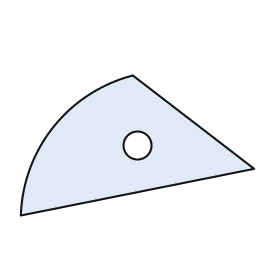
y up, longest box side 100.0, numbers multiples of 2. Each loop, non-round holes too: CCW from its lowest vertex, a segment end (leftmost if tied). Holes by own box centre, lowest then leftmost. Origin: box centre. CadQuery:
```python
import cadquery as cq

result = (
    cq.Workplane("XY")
    .moveTo(-50.0, -30.0)
    .lineTo(50.0, -10.0)
    .lineTo(-2.0, 30.0)
    .threePointArc((-36.0, 8.0), (-50.0, -30.0))
    .close()
    .moveTo(0.0, 0.0)
    .circle(6.0)
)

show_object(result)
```